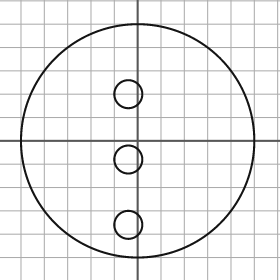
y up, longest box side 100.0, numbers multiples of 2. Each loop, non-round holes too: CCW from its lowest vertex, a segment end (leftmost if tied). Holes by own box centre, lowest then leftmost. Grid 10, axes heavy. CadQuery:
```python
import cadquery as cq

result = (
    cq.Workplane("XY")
    .moveTo(0.0, 0.0)
    .circle(50.0)
    .moveTo(-4.0, -36.0)
    .circle(6.0)
    .moveTo(-4.0, -8.0)
    .circle(6.0)
    .moveTo(-4.0, 20.0)
    .circle(6.0)
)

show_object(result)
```